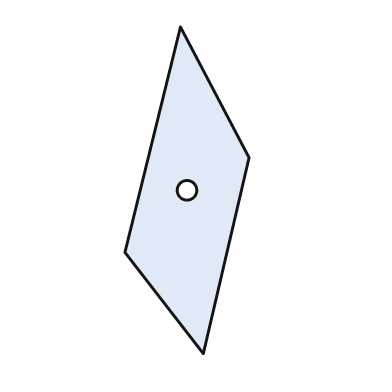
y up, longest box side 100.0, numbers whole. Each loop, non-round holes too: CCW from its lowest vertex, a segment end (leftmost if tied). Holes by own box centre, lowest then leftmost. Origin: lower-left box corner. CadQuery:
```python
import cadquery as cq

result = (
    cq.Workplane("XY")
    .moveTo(24.0, 0.0)
    .lineTo(38.0, 60.0)
    .lineTo(17.0, 100.0)
    .lineTo(0.0, 31.0)
    .close()
    .moveTo(19.0, 50.0)
    .circle(3.0)
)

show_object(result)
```